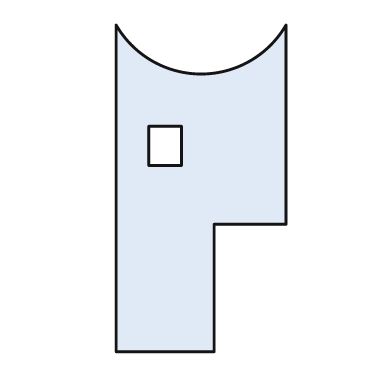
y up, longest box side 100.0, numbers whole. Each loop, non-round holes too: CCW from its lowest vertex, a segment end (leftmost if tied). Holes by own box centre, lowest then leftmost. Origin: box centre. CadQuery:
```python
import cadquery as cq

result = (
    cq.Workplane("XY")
    .moveTo(-26.0, -50.0)
    .lineTo(4.0, -50.0)
    .lineTo(4.0, -11.0)
    .lineTo(26.0, -11.0)
    .lineTo(26.0, 50.0)
    .threePointArc((0.0, 35.0), (-26.0, 50.0))
    .close()
    .moveTo(-16.0, 7.0)
    .lineTo(-6.0, 7.0)
    .lineTo(-6.0, 19.0)
    .lineTo(-16.0, 19.0)
    .close()
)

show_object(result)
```